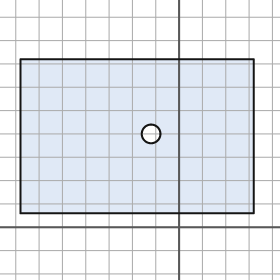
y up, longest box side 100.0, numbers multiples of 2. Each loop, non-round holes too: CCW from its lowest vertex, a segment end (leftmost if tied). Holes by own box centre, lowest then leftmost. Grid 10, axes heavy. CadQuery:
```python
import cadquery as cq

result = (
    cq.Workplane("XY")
    .moveTo(-68.0, 6.0)
    .lineTo(32.0, 6.0)
    .lineTo(32.0, 72.0)
    .lineTo(-68.0, 72.0)
    .close()
    .moveTo(-12.0, 40.0)
    .circle(4.0)
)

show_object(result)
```